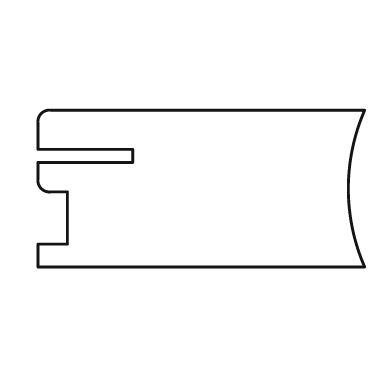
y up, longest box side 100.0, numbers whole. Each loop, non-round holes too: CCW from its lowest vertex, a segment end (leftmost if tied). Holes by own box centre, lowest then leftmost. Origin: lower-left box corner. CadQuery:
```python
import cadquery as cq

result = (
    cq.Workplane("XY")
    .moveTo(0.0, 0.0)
    .lineTo(100.0, 0.0)
    .threePointArc((95.0, 24.0), (100.0, 48.0))
    .lineTo(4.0, 48.0)
    .threePointArc((1.0, 47.0), (0.0, 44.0))
    .lineTo(0.0, 36.0)
    .lineTo(29.0, 36.0)
    .lineTo(29.0, 32.0)
    .lineTo(0.0, 32.0)
    .lineTo(0.0, 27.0)
    .threePointArc((1.0, 24.0), (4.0, 23.0))
    .lineTo(9.0, 23.0)
    .lineTo(9.0, 7.0)
    .lineTo(0.0, 7.0)
    .close()
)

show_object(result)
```